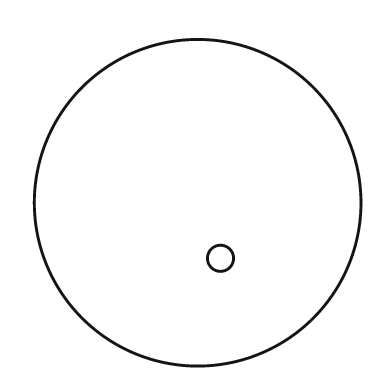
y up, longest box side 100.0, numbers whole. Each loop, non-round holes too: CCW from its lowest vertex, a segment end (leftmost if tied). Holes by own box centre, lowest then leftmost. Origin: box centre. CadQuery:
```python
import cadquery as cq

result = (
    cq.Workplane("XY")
    .moveTo(0.0, 0.0)
    .circle(50.0)
    .moveTo(7.0, -17.0)
    .circle(4.0)
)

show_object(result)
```